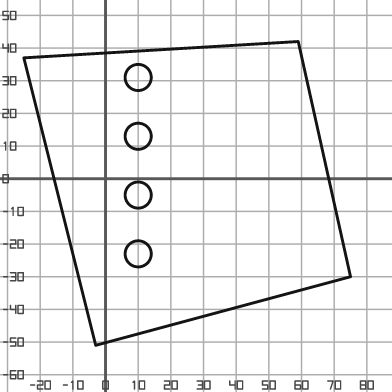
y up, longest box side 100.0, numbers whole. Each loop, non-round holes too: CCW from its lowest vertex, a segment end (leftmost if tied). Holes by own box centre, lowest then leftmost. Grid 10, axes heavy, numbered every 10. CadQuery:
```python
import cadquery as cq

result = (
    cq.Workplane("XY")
    .moveTo(-3.0, -51.0)
    .lineTo(75.0, -30.0)
    .lineTo(59.0, 42.0)
    .lineTo(-25.0, 37.0)
    .close()
    .moveTo(10.0, -23.0)
    .circle(4.0)
    .moveTo(10.0, -5.0)
    .circle(4.0)
    .moveTo(10.0, 13.0)
    .circle(4.0)
    .moveTo(10.0, 31.0)
    .circle(4.0)
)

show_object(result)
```